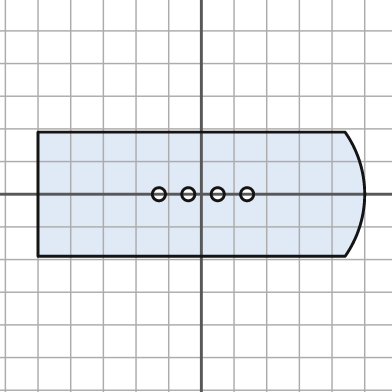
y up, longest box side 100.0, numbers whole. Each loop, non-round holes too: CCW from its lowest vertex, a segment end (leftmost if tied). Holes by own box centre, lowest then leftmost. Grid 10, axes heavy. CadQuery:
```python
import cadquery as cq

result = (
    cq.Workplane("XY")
    .moveTo(-50.0, -19.0)
    .lineTo(44.0, -19.0)
    .threePointArc((50.0, 0.0), (44.0, 19.0))
    .lineTo(-50.0, 19.0)
    .close()
    .moveTo(-13.0, 0.0)
    .circle(2.0)
    .moveTo(-4.0, 0.0)
    .circle(2.0)
    .moveTo(5.0, 0.0)
    .circle(2.0)
    .moveTo(14.0, 0.0)
    .circle(2.0)
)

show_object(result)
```